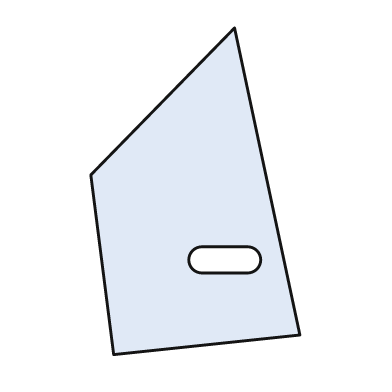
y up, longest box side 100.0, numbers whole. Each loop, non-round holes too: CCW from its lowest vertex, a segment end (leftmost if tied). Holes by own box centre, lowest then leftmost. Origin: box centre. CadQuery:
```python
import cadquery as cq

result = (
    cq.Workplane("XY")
    .moveTo(-25.0, -50.0)
    .lineTo(32.0, -44.0)
    .lineTo(12.0, 50.0)
    .lineTo(-32.0, 5.0)
    .close()
    .moveTo(2.0, -25.0)
    .lineTo(16.0, -25.0)
    .threePointArc((20.0, -21.0), (16.0, -17.0))
    .lineTo(2.0, -17.0)
    .threePointArc((-2.0, -21.0), (2.0, -25.0))
    .close()
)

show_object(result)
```